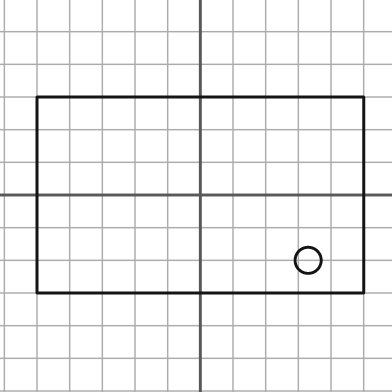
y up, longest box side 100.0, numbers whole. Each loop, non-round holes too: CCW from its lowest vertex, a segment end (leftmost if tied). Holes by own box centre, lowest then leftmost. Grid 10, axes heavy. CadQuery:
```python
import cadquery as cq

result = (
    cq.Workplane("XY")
    .moveTo(-50.0, -30.0)
    .lineTo(50.0, -30.0)
    .lineTo(50.0, 30.0)
    .lineTo(-50.0, 30.0)
    .close()
    .moveTo(33.0, -20.0)
    .circle(4.0)
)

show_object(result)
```